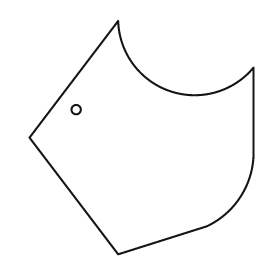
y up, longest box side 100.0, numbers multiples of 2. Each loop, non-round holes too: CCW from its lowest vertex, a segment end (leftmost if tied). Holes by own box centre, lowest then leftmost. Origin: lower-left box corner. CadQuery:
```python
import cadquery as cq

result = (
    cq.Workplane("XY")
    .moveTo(38.0, 0.0)
    .lineTo(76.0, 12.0)
    .threePointArc((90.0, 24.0), (96.0, 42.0))
    .lineTo(96.0, 80.0)
    .threePointArc((60.0, 70.0), (38.0, 100.0))
    .lineTo(0.0, 50.0)
    .close()
    .moveTo(20.0, 62.0)
    .circle(2.0)
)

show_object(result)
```